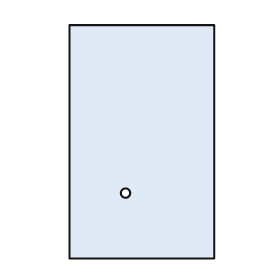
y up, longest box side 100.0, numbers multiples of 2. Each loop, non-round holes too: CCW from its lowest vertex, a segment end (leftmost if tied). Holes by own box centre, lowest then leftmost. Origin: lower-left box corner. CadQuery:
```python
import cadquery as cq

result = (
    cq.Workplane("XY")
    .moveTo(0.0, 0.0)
    .lineTo(62.0, 0.0)
    .lineTo(62.0, 100.0)
    .lineTo(0.0, 100.0)
    .close()
    .moveTo(24.0, 28.0)
    .circle(2.0)
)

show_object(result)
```